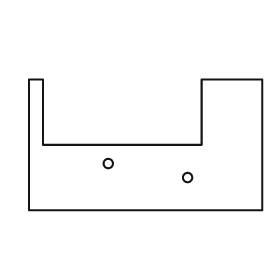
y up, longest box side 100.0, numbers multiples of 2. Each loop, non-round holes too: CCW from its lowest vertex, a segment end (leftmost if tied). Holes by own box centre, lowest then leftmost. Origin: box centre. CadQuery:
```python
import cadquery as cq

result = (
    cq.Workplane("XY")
    .moveTo(-50.0, -28.0)
    .lineTo(50.0, -28.0)
    .lineTo(50.0, 28.0)
    .lineTo(24.0, 28.0)
    .lineTo(24.0, 0.0)
    .lineTo(-44.0, 0.0)
    .lineTo(-44.0, 28.0)
    .lineTo(-50.0, 28.0)
    .close()
    .moveTo(18.0, -14.0)
    .circle(2.0)
    .moveTo(-16.0, -8.0)
    .circle(2.0)
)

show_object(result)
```